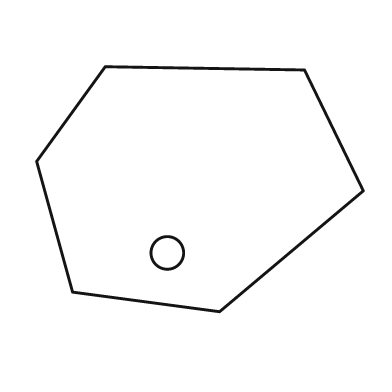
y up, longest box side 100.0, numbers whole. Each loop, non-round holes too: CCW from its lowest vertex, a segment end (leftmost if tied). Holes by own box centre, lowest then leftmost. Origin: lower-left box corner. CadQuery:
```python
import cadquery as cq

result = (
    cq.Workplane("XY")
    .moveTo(56.0, 0.0)
    .lineTo(100.0, 37.0)
    .lineTo(82.0, 74.0)
    .lineTo(21.0, 75.0)
    .lineTo(0.0, 46.0)
    .lineTo(11.0, 6.0)
    .close()
    .moveTo(40.0, 18.0)
    .circle(5.0)
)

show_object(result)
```